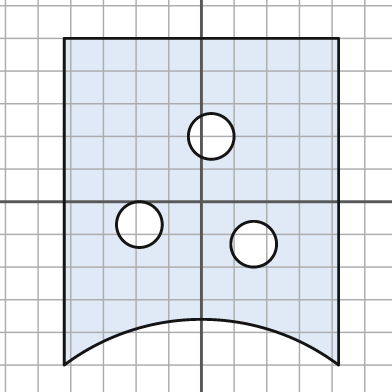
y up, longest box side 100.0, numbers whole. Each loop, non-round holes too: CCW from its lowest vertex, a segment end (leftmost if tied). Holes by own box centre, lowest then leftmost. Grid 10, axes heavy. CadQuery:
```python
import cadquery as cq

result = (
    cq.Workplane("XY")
    .moveTo(-42.0, -50.0)
    .threePointArc((0.0, -36.0), (42.0, -50.0))
    .lineTo(42.0, 50.0)
    .lineTo(-42.0, 50.0)
    .close()
    .moveTo(16.0, -13.0)
    .circle(7.0)
    .moveTo(-19.0, -7.0)
    .circle(7.0)
    .moveTo(3.0, 20.0)
    .circle(7.0)
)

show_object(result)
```